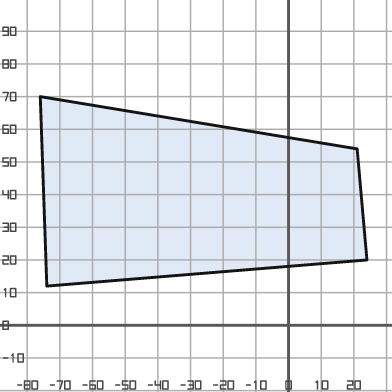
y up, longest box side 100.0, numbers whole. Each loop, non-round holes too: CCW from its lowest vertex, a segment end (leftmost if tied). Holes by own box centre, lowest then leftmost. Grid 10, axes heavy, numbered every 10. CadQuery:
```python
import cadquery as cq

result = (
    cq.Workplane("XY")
    .moveTo(-74.0, 12.0)
    .lineTo(24.0, 20.0)
    .lineTo(21.0, 54.0)
    .lineTo(-76.0, 70.0)
    .close()
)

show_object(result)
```